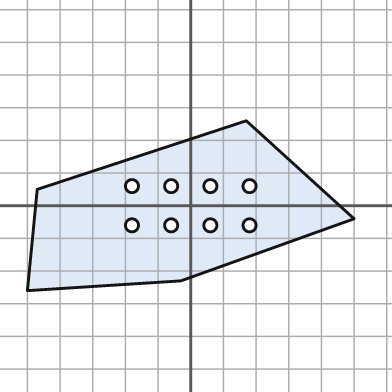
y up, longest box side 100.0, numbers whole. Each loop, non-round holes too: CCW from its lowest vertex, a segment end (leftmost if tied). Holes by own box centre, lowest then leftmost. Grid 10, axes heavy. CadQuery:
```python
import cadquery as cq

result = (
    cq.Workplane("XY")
    .moveTo(-50.0, -26.0)
    .lineTo(-3.0, -23.0)
    .lineTo(50.0, -4.0)
    .lineTo(17.0, 26.0)
    .lineTo(-47.0, 5.0)
    .close()
    .moveTo(-18.0, -6.0)
    .circle(2.0)
    .moveTo(-6.0, -6.0)
    .circle(2.0)
    .moveTo(6.0, -6.0)
    .circle(2.0)
    .moveTo(18.0, -6.0)
    .circle(2.0)
    .moveTo(-18.0, 6.0)
    .circle(2.0)
    .moveTo(-6.0, 6.0)
    .circle(2.0)
    .moveTo(6.0, 6.0)
    .circle(2.0)
    .moveTo(18.0, 6.0)
    .circle(2.0)
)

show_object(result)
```